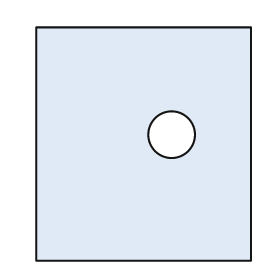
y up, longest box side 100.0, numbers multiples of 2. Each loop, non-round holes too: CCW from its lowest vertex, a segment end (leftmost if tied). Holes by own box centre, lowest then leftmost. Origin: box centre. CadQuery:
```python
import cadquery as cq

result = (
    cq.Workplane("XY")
    .moveTo(-46.0, -50.0)
    .lineTo(46.0, -50.0)
    .lineTo(46.0, 50.0)
    .lineTo(-46.0, 50.0)
    .close()
    .moveTo(12.0, 4.0)
    .circle(10.0)
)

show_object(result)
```